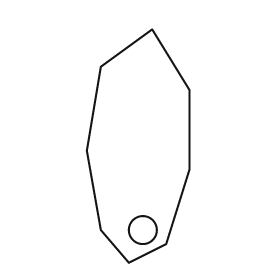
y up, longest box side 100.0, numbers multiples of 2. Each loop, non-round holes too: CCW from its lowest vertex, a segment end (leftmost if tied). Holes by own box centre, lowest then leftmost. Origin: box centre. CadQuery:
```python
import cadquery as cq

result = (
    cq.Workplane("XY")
    .moveTo(-4.0, -50.0)
    .lineTo(12.0, -42.0)
    .lineTo(22.0, -10.0)
    .lineTo(22.0, 24.0)
    .lineTo(6.0, 50.0)
    .lineTo(-16.0, 34.0)
    .lineTo(-22.0, -2.0)
    .lineTo(-16.0, -36.0)
    .close()
    .moveTo(2.0, -36.0)
    .circle(6.0)
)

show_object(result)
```